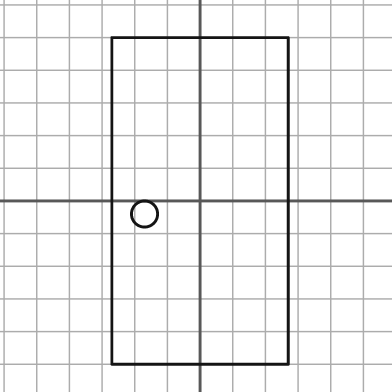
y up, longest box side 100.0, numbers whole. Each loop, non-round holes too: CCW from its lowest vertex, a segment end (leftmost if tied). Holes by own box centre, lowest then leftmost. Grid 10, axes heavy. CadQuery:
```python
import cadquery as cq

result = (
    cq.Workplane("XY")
    .moveTo(-27.0, -50.0)
    .lineTo(27.0, -50.0)
    .lineTo(27.0, 50.0)
    .lineTo(-27.0, 50.0)
    .close()
    .moveTo(-17.0, -4.0)
    .circle(4.0)
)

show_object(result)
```